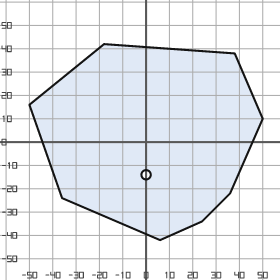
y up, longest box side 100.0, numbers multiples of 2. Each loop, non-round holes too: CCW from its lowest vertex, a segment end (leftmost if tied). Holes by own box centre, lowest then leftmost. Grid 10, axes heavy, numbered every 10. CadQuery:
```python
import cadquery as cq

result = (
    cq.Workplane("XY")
    .moveTo(6.0, -42.0)
    .lineTo(24.0, -34.0)
    .lineTo(36.0, -22.0)
    .lineTo(50.0, 10.0)
    .lineTo(38.0, 38.0)
    .lineTo(-18.0, 42.0)
    .lineTo(-50.0, 16.0)
    .lineTo(-36.0, -24.0)
    .close()
    .moveTo(0.0, -14.0)
    .circle(2.0)
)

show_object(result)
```